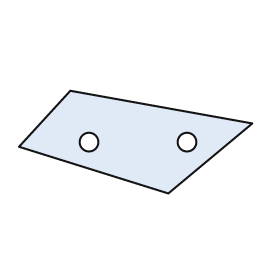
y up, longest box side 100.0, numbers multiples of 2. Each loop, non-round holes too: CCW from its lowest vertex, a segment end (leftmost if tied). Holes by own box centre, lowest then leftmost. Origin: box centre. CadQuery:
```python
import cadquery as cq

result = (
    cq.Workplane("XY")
    .moveTo(14.0, -22.0)
    .lineTo(50.0, 8.0)
    .lineTo(-28.0, 22.0)
    .lineTo(-50.0, -2.0)
    .close()
    .moveTo(-20.0, 0.0)
    .circle(4.0)
    .moveTo(22.0, 0.0)
    .circle(4.0)
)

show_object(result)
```